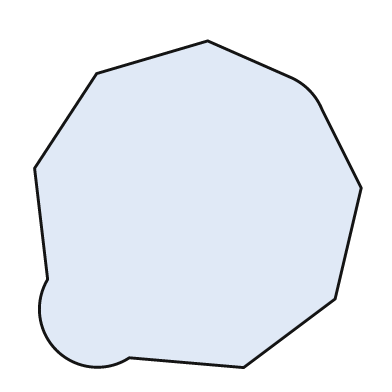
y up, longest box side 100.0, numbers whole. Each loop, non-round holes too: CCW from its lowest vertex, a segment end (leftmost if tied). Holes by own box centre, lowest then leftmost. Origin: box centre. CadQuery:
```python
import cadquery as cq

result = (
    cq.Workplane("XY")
    .moveTo(14.0, -50.0)
    .lineTo(42.0, -29.0)
    .lineTo(50.0, 5.0)
    .lineTo(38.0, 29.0)
    .threePointArc((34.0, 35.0), (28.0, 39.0))
    .lineTo(3.0, 50.0)
    .lineTo(-31.0, 40.0)
    .lineTo(-50.0, 11.0)
    .lineTo(-46.0, -23.0)
    .threePointArc((-43.0, -45.0), (-21.0, -47.0))
    .close()
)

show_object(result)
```